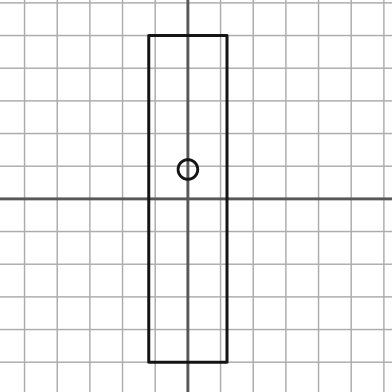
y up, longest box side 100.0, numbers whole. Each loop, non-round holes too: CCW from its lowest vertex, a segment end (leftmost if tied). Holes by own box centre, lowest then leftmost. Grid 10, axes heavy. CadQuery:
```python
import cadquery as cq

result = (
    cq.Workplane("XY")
    .moveTo(-12.0, -50.0)
    .lineTo(12.0, -50.0)
    .lineTo(12.0, 50.0)
    .lineTo(-12.0, 50.0)
    .close()
    .moveTo(0.0, 9.0)
    .circle(3.0)
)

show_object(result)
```